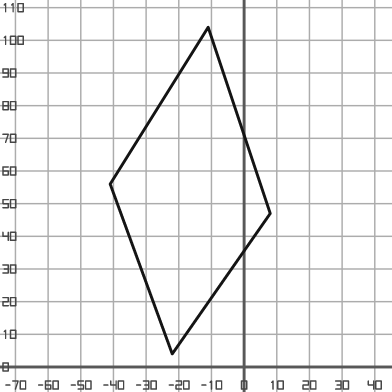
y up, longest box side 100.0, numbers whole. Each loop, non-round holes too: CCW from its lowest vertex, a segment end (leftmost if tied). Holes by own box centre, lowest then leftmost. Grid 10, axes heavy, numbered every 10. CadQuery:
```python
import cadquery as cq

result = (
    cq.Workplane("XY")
    .moveTo(-22.0, 4.0)
    .lineTo(8.0, 47.0)
    .lineTo(-11.0, 104.0)
    .lineTo(-41.0, 56.0)
    .close()
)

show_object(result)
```